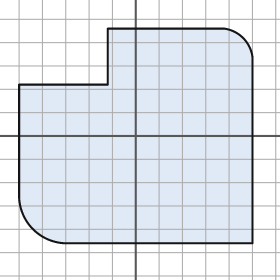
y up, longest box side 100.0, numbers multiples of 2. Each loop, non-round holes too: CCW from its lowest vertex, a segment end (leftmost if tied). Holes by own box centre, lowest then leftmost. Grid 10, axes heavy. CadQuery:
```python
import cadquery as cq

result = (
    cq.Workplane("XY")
    .moveTo(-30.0, -46.0)
    .lineTo(50.0, -46.0)
    .lineTo(50.0, 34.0)
    .threePointArc((46.0, 42.0), (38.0, 46.0))
    .lineTo(-12.0, 46.0)
    .lineTo(-12.0, 22.0)
    .lineTo(-50.0, 22.0)
    .lineTo(-50.0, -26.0)
    .threePointArc((-44.0, -40.0), (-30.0, -46.0))
    .close()
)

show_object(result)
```